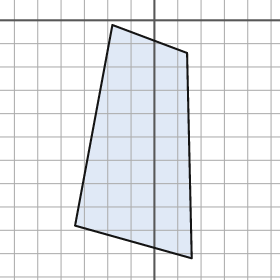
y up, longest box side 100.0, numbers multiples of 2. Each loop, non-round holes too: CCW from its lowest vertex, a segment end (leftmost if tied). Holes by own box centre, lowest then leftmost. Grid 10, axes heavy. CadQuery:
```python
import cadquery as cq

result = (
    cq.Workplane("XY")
    .moveTo(16.0, -102.0)
    .lineTo(14.0, -14.0)
    .lineTo(-18.0, -2.0)
    .lineTo(-34.0, -88.0)
    .close()
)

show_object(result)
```